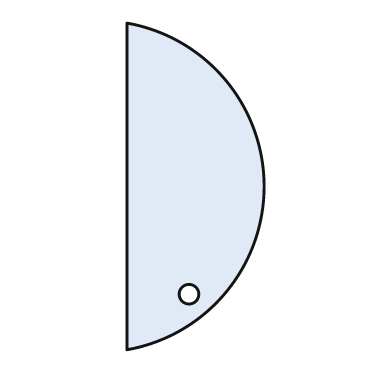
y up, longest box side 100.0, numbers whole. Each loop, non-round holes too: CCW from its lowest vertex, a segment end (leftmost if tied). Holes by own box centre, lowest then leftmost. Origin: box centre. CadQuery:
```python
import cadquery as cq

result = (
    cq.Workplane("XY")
    .moveTo(-21.0, -50.0)
    .threePointArc((21.0, 0.0), (-21.0, 50.0))
    .close()
    .moveTo(-2.0, -33.0)
    .circle(3.0)
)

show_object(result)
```